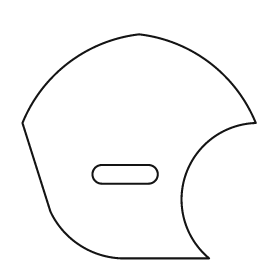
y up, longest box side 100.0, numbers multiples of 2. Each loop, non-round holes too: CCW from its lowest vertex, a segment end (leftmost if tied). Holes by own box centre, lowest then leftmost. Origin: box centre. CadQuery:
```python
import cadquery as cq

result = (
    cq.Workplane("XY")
    .moveTo(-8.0, -48.0)
    .lineTo(30.0, -48.0)
    .threePointArc((20.0, -12.0), (50.0, 10.0))
    .threePointArc((30.0, 36.0), (0.0, 48.0))
    .threePointArc((-30.0, 36.0), (-50.0, 10.0))
    .lineTo(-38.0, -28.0)
    .threePointArc((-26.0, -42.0), (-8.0, -48.0))
    .close()
    .moveTo(-16.0, -16.0)
    .lineTo(4.0, -16.0)
    .threePointArc((8.0, -12.0), (4.0, -8.0))
    .lineTo(-16.0, -8.0)
    .threePointArc((-20.0, -12.0), (-16.0, -16.0))
    .close()
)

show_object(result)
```